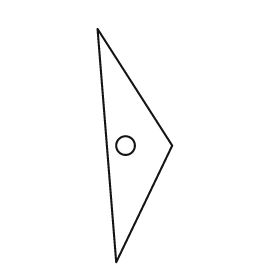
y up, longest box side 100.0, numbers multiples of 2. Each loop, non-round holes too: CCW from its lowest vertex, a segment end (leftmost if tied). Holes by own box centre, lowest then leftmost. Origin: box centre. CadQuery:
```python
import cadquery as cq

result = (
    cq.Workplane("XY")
    .moveTo(-8.0, -50.0)
    .lineTo(16.0, 0.0)
    .lineTo(-16.0, 50.0)
    .close()
    .moveTo(-4.0, 0.0)
    .circle(4.0)
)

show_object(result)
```